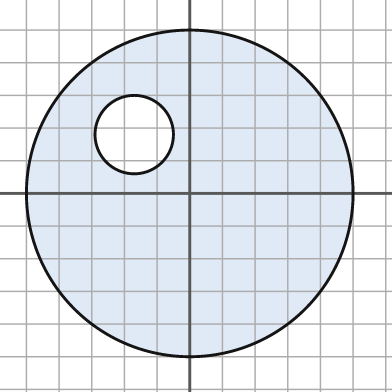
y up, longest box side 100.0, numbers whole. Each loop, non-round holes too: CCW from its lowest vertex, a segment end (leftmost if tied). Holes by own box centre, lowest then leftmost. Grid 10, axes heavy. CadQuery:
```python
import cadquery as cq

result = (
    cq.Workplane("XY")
    .moveTo(0.0, 0.0)
    .circle(50.0)
    .moveTo(-17.0, 18.0)
    .circle(12.0)
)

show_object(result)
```